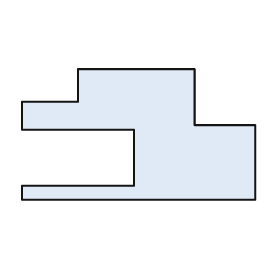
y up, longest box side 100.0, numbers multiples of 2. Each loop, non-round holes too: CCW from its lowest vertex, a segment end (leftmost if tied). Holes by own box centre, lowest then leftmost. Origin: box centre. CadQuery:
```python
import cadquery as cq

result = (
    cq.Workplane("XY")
    .moveTo(-50.0, -28.0)
    .lineTo(50.0, -28.0)
    .lineTo(50.0, 4.0)
    .lineTo(24.0, 4.0)
    .lineTo(24.0, 28.0)
    .lineTo(-26.0, 28.0)
    .lineTo(-26.0, 14.0)
    .lineTo(-50.0, 14.0)
    .lineTo(-50.0, 2.0)
    .lineTo(-2.0, 2.0)
    .lineTo(-2.0, -22.0)
    .lineTo(-50.0, -22.0)
    .close()
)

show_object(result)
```